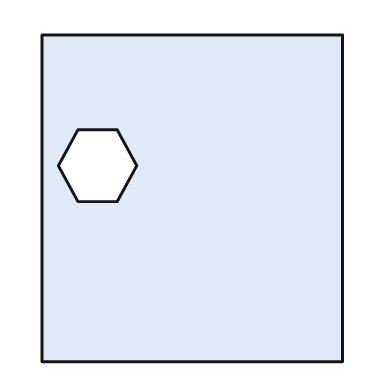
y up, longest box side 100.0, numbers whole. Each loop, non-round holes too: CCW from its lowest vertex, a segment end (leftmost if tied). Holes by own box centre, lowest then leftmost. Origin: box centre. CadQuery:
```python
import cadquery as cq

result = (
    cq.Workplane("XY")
    .moveTo(-46.0, -50.0)
    .lineTo(46.0, -50.0)
    .lineTo(46.0, 50.0)
    .lineTo(-46.0, 50.0)
    .close()
    .moveTo(-35.0, -1.0)
    .lineTo(-23.0, -1.0)
    .lineTo(-17.0, 10.0)
    .lineTo(-23.0, 21.0)
    .lineTo(-35.0, 21.0)
    .lineTo(-41.0, 10.0)
    .close()
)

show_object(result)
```